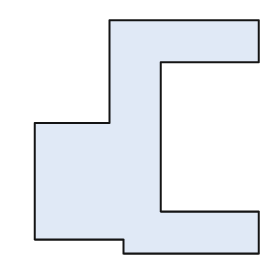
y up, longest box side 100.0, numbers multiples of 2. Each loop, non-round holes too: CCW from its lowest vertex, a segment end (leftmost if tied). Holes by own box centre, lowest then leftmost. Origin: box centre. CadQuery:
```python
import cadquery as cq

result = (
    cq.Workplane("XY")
    .moveTo(-10.0, -50.0)
    .lineTo(48.0, -50.0)
    .lineTo(48.0, -32.0)
    .lineTo(6.0, -32.0)
    .lineTo(6.0, 32.0)
    .lineTo(48.0, 32.0)
    .lineTo(48.0, 50.0)
    .lineTo(-16.0, 50.0)
    .lineTo(-16.0, 6.0)
    .lineTo(-48.0, 6.0)
    .lineTo(-48.0, -44.0)
    .lineTo(-10.0, -44.0)
    .close()
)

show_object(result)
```